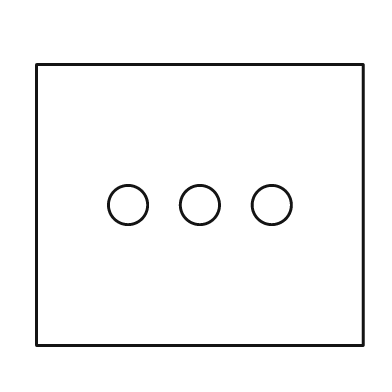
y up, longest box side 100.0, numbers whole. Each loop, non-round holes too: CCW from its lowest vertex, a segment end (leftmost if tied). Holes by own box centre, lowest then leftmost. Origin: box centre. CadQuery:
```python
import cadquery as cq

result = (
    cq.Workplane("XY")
    .moveTo(-50.0, -43.0)
    .lineTo(50.0, -43.0)
    .lineTo(50.0, 43.0)
    .lineTo(-50.0, 43.0)
    .close()
    .moveTo(-22.0, 0.0)
    .circle(6.0)
    .moveTo(0.0, 0.0)
    .circle(6.0)
    .moveTo(22.0, 0.0)
    .circle(6.0)
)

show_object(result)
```